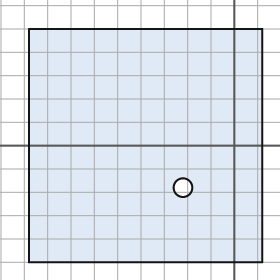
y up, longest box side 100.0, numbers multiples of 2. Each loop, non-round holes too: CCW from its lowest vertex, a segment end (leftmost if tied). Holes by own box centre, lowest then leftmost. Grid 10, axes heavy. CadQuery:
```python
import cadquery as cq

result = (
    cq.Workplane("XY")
    .moveTo(-88.0, -50.0)
    .lineTo(12.0, -50.0)
    .lineTo(12.0, 50.0)
    .lineTo(-88.0, 50.0)
    .close()
    .moveTo(-22.0, -18.0)
    .circle(4.0)
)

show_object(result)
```